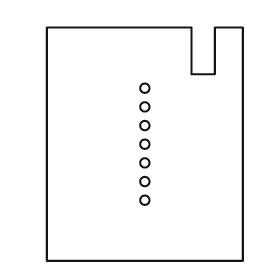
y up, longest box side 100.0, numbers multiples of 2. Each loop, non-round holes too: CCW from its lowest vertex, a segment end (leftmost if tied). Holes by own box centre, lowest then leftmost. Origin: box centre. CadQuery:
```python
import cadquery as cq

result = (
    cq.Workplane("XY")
    .moveTo(-42.0, -50.0)
    .lineTo(42.0, -50.0)
    .lineTo(42.0, 50.0)
    .lineTo(30.0, 50.0)
    .lineTo(30.0, 30.0)
    .lineTo(20.0, 30.0)
    .lineTo(20.0, 50.0)
    .lineTo(-42.0, 50.0)
    .close()
    .moveTo(0.0, -24.0)
    .circle(2.0)
    .moveTo(0.0, -16.0)
    .circle(2.0)
    .moveTo(0.0, -8.0)
    .circle(2.0)
    .moveTo(0.0, 0.0)
    .circle(2.0)
    .moveTo(0.0, 8.0)
    .circle(2.0)
    .moveTo(0.0, 16.0)
    .circle(2.0)
    .moveTo(0.0, 24.0)
    .circle(2.0)
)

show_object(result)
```